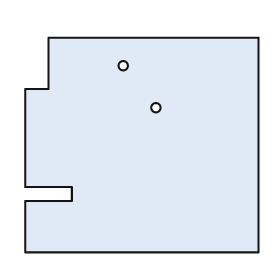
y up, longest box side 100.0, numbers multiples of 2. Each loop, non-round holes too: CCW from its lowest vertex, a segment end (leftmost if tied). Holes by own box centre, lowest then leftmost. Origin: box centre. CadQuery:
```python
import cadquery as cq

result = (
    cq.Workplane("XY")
    .moveTo(-50.0, -46.0)
    .lineTo(50.0, -46.0)
    .lineTo(50.0, 46.0)
    .lineTo(-40.0, 46.0)
    .lineTo(-40.0, 24.0)
    .lineTo(-50.0, 24.0)
    .lineTo(-50.0, -18.0)
    .lineTo(-30.0, -18.0)
    .lineTo(-30.0, -24.0)
    .lineTo(-50.0, -24.0)
    .close()
    .moveTo(6.0, 16.0)
    .circle(2.0)
    .moveTo(-8.0, 34.0)
    .circle(2.0)
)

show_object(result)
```